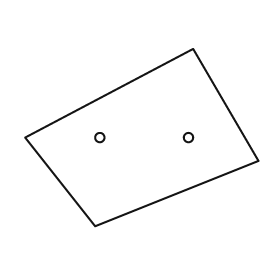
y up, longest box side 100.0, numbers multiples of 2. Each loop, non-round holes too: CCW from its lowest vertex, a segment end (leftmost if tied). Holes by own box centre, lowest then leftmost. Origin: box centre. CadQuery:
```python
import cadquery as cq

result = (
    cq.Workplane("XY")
    .moveTo(-20.0, -38.0)
    .lineTo(50.0, -10.0)
    .lineTo(22.0, 38.0)
    .lineTo(-50.0, 0.0)
    .close()
    .moveTo(-18.0, 0.0)
    .circle(2.0)
    .moveTo(20.0, 0.0)
    .circle(2.0)
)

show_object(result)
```